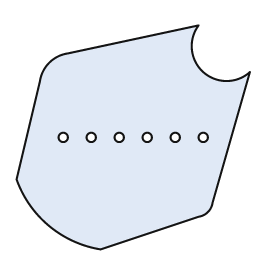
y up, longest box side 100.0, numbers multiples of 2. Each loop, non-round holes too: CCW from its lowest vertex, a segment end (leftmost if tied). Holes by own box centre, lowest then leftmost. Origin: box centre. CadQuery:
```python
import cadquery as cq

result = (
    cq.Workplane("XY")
    .moveTo(-14.0, -48.0)
    .lineTo(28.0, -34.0)
    .threePointArc((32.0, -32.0), (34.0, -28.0))
    .lineTo(50.0, 28.0)
    .threePointArc((30.0, 28.0), (28.0, 48.0))
    .lineTo(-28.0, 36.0)
    .threePointArc((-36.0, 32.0), (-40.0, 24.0))
    .lineTo(-50.0, -18.0)
    .threePointArc((-36.0, -38.0), (-14.0, -48.0))
    .close()
    .moveTo(-30.0, 0.0)
    .circle(2.0)
    .moveTo(-18.0, 0.0)
    .circle(2.0)
    .moveTo(-6.0, 0.0)
    .circle(2.0)
    .moveTo(6.0, 0.0)
    .circle(2.0)
    .moveTo(18.0, 0.0)
    .circle(2.0)
    .moveTo(30.0, 0.0)
    .circle(2.0)
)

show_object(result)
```